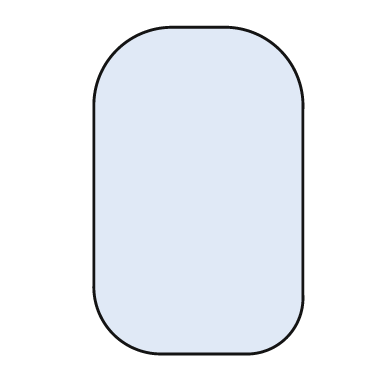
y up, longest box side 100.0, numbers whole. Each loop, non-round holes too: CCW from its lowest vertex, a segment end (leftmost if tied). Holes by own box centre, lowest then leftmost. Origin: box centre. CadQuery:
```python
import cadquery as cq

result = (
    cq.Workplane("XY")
    .moveTo(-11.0, -50.0)
    .lineTo(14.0, -50.0)
    .threePointArc((27.0, -45.0), (32.0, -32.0))
    .lineTo(32.0, 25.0)
    .threePointArc((25.0, 43.0), (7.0, 50.0))
    .lineTo(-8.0, 50.0)
    .threePointArc((-25.0, 43.0), (-32.0, 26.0))
    .lineTo(-32.0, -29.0)
    .threePointArc((-26.0, -44.0), (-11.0, -50.0))
    .close()
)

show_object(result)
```